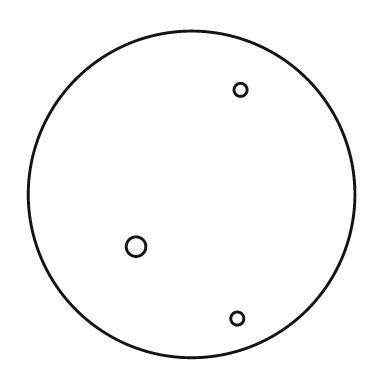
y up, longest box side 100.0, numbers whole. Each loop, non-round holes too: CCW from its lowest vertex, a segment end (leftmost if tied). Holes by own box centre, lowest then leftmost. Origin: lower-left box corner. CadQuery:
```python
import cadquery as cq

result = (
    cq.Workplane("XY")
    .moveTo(50.0, 50.0)
    .circle(50.0)
    .moveTo(64.0, 12.0)
    .circle(2.0)
    .moveTo(33.0, 34.0)
    .circle(3.0)
    .moveTo(65.0, 82.0)
    .circle(2.0)
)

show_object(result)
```